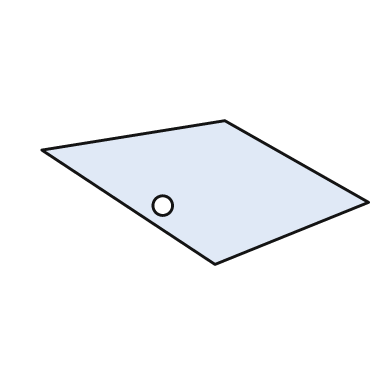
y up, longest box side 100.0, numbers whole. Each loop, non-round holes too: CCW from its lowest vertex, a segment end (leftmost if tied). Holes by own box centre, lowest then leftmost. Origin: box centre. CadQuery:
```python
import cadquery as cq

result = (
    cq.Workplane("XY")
    .moveTo(3.0, -22.0)
    .lineTo(50.0, -3.0)
    .lineTo(6.0, 22.0)
    .lineTo(-50.0, 13.0)
    .close()
    .moveTo(-13.0, -4.0)
    .circle(3.0)
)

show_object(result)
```